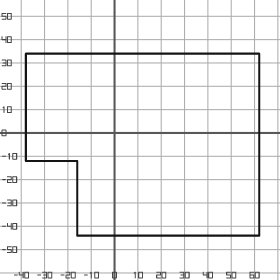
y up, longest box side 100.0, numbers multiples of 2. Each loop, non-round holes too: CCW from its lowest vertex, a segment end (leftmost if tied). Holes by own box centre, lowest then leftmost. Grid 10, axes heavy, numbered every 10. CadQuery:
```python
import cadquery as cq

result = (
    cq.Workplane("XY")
    .moveTo(-16.0, -44.0)
    .lineTo(62.0, -44.0)
    .lineTo(62.0, 34.0)
    .lineTo(-38.0, 34.0)
    .lineTo(-38.0, -12.0)
    .lineTo(-16.0, -12.0)
    .close()
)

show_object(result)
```